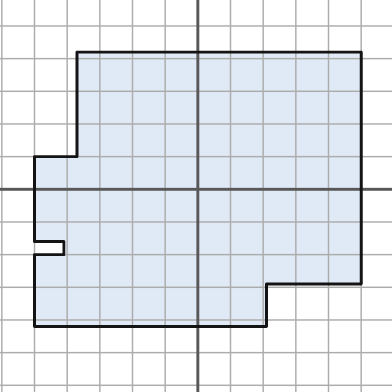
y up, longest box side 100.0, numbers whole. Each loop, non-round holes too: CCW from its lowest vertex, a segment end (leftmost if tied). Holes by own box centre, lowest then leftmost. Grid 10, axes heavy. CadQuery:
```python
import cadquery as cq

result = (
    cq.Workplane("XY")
    .moveTo(-50.0, -42.0)
    .lineTo(21.0, -42.0)
    .lineTo(21.0, -29.0)
    .lineTo(50.0, -29.0)
    .lineTo(50.0, 42.0)
    .lineTo(-37.0, 42.0)
    .lineTo(-37.0, 10.0)
    .lineTo(-50.0, 10.0)
    .lineTo(-50.0, -16.0)
    .lineTo(-41.0, -16.0)
    .lineTo(-41.0, -20.0)
    .lineTo(-50.0, -20.0)
    .close()
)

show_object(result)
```